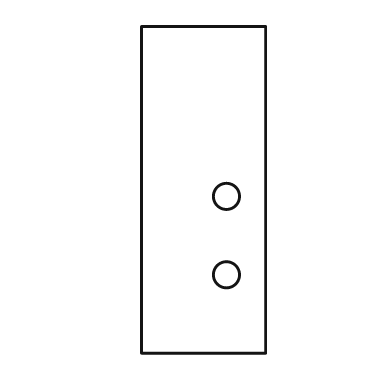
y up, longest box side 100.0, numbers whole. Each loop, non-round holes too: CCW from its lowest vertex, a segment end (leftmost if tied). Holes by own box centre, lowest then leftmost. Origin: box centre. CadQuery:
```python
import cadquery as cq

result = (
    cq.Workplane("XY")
    .moveTo(-19.0, -50.0)
    .lineTo(19.0, -50.0)
    .lineTo(19.0, 50.0)
    .lineTo(-19.0, 50.0)
    .close()
    .moveTo(7.0, -26.0)
    .circle(4.0)
    .moveTo(7.0, -2.0)
    .circle(4.0)
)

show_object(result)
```